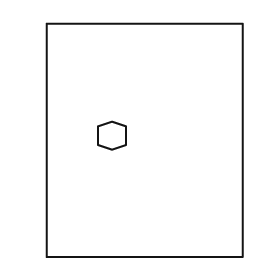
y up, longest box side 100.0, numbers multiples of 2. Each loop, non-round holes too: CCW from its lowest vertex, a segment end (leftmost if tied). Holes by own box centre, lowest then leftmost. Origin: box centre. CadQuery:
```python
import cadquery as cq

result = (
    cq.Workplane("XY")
    .moveTo(-42.0, -50.0)
    .lineTo(42.0, -50.0)
    .lineTo(42.0, 50.0)
    .lineTo(-42.0, 50.0)
    .close()
    .moveTo(-14.0, -4.0)
    .lineTo(-8.0, -2.0)
    .lineTo(-8.0, 6.0)
    .lineTo(-14.0, 8.0)
    .lineTo(-20.0, 6.0)
    .lineTo(-20.0, -2.0)
    .close()
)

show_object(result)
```